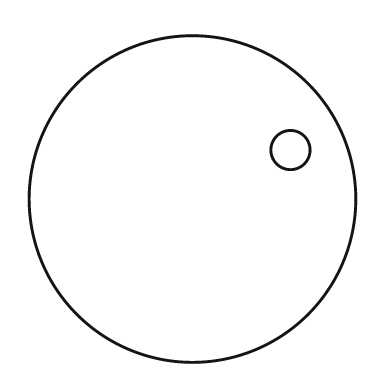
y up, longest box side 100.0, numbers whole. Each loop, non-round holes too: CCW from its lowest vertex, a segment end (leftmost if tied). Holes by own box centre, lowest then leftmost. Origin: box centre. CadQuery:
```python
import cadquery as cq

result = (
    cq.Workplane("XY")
    .moveTo(0.0, 0.0)
    .circle(50.0)
    .moveTo(30.0, 15.0)
    .circle(6.0)
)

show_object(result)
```